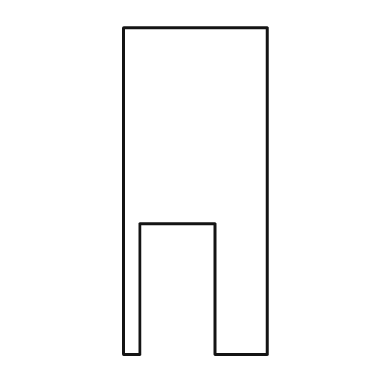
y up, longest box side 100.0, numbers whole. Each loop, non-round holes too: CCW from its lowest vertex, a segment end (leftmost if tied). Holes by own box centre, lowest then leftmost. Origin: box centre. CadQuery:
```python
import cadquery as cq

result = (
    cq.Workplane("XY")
    .moveTo(-22.0, -50.0)
    .lineTo(-17.0, -50.0)
    .lineTo(-17.0, -10.0)
    .lineTo(6.0, -10.0)
    .lineTo(6.0, -50.0)
    .lineTo(22.0, -50.0)
    .lineTo(22.0, 50.0)
    .lineTo(-22.0, 50.0)
    .close()
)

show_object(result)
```